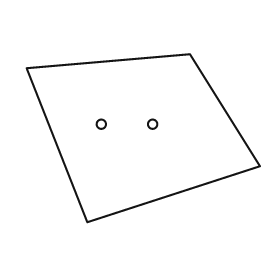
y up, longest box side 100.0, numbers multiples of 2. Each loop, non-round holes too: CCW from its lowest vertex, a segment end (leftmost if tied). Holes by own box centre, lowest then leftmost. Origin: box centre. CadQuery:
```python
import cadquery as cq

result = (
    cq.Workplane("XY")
    .moveTo(-24.0, -36.0)
    .lineTo(50.0, -12.0)
    .lineTo(20.0, 36.0)
    .lineTo(-50.0, 30.0)
    .close()
    .moveTo(-18.0, 6.0)
    .circle(2.0)
    .moveTo(4.0, 6.0)
    .circle(2.0)
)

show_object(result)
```